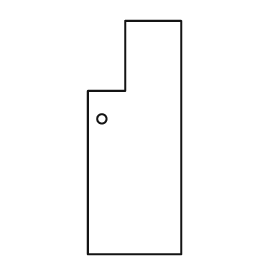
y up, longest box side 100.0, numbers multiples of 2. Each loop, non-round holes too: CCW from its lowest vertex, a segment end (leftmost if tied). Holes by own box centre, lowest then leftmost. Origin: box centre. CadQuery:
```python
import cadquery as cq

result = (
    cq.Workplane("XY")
    .moveTo(-20.0, -50.0)
    .lineTo(20.0, -50.0)
    .lineTo(20.0, 50.0)
    .lineTo(-4.0, 50.0)
    .lineTo(-4.0, 20.0)
    .lineTo(-20.0, 20.0)
    .close()
    .moveTo(-14.0, 8.0)
    .circle(2.0)
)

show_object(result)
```